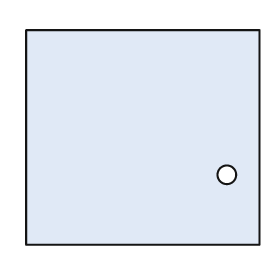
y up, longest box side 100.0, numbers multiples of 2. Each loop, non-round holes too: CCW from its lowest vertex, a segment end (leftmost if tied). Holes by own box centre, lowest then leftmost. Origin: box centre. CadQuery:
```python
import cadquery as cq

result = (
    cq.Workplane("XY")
    .moveTo(-50.0, -46.0)
    .lineTo(50.0, -46.0)
    .lineTo(50.0, 46.0)
    .lineTo(-50.0, 46.0)
    .close()
    .moveTo(36.0, -16.0)
    .circle(4.0)
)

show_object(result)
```